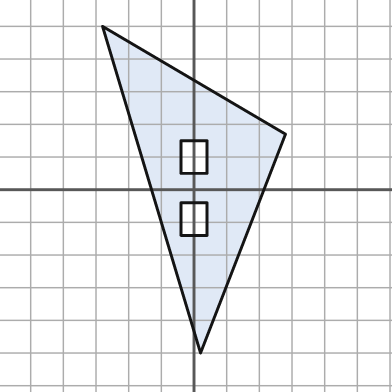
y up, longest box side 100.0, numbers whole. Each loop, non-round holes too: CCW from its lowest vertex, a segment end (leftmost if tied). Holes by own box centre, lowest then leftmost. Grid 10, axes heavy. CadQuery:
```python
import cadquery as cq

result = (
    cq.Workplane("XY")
    .moveTo(2.0, -50.0)
    .lineTo(28.0, 17.0)
    .lineTo(-28.0, 50.0)
    .close()
    .moveTo(-4.0, -14.0)
    .lineTo(4.0, -14.0)
    .lineTo(4.0, -4.0)
    .lineTo(-4.0, -4.0)
    .close()
    .moveTo(-4.0, 5.0)
    .lineTo(4.0, 5.0)
    .lineTo(4.0, 15.0)
    .lineTo(-4.0, 15.0)
    .close()
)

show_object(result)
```